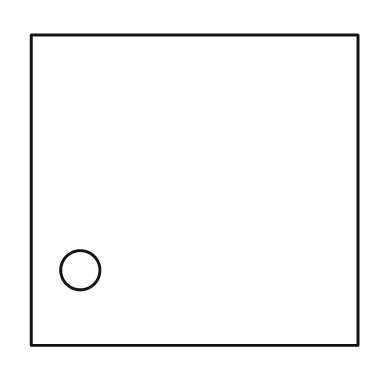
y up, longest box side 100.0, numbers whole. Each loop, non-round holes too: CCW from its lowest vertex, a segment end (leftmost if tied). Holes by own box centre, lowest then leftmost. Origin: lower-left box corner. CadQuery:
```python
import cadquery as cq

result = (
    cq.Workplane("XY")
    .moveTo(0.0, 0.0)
    .lineTo(100.0, 0.0)
    .lineTo(100.0, 95.0)
    .lineTo(0.0, 95.0)
    .close()
    .moveTo(15.0, 23.0)
    .circle(6.0)
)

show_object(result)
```